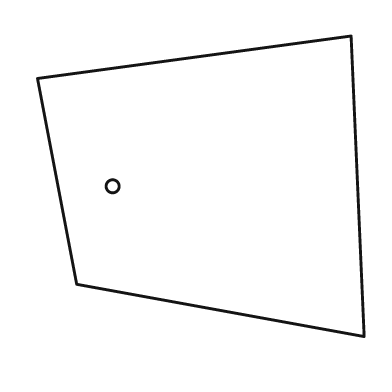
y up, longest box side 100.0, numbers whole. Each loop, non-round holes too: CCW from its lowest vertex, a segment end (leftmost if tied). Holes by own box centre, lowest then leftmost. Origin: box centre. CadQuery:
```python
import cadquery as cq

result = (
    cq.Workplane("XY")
    .moveTo(50.0, -46.0)
    .lineTo(46.0, 46.0)
    .lineTo(-50.0, 33.0)
    .lineTo(-38.0, -30.0)
    .close()
    .moveTo(-27.0, 0.0)
    .circle(2.0)
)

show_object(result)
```